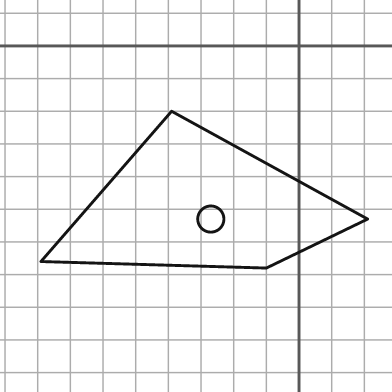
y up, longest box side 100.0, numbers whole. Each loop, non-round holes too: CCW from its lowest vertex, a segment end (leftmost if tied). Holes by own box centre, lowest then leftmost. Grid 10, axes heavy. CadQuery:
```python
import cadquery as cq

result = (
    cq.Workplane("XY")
    .moveTo(-10.0, -68.0)
    .lineTo(21.0, -53.0)
    .lineTo(-39.0, -20.0)
    .lineTo(-79.0, -66.0)
    .close()
    .moveTo(-27.0, -53.0)
    .circle(4.0)
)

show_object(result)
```